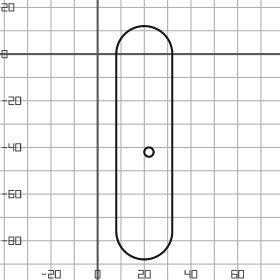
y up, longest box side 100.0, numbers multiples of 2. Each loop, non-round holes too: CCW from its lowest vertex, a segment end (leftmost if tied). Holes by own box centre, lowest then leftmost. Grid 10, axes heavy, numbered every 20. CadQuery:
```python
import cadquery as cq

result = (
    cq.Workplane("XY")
    .moveTo(8.0, -76.0)
    .threePointArc((20.0, -88.0), (32.0, -76.0))
    .lineTo(32.0, 0.0)
    .threePointArc((20.0, 12.0), (8.0, 0.0))
    .close()
    .moveTo(22.0, -42.0)
    .circle(2.0)
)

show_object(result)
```